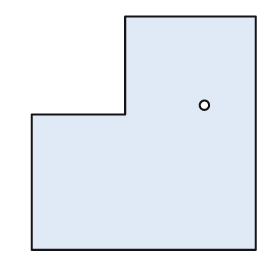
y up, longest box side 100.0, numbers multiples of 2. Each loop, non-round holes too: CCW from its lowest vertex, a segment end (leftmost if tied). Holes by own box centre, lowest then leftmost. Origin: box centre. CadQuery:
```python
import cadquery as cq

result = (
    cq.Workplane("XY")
    .moveTo(-48.0, -50.0)
    .lineTo(48.0, -50.0)
    .lineTo(48.0, 50.0)
    .lineTo(-8.0, 50.0)
    .lineTo(-8.0, 8.0)
    .lineTo(-48.0, 8.0)
    .close()
    .moveTo(26.0, 12.0)
    .circle(2.0)
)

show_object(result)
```